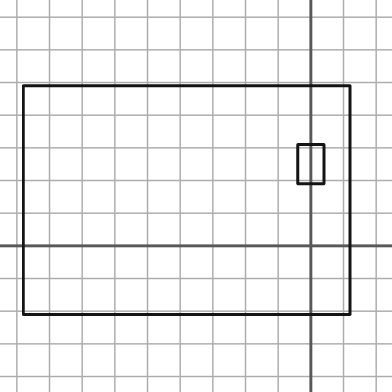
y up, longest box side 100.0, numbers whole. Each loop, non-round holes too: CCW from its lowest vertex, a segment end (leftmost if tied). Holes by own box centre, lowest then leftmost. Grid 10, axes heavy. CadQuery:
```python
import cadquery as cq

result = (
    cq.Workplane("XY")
    .moveTo(-88.0, -21.0)
    .lineTo(12.0, -21.0)
    .lineTo(12.0, 49.0)
    .lineTo(-88.0, 49.0)
    .close()
    .moveTo(-4.0, 19.0)
    .lineTo(4.0, 19.0)
    .lineTo(4.0, 31.0)
    .lineTo(-4.0, 31.0)
    .close()
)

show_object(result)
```